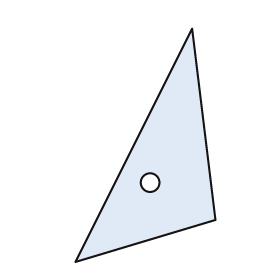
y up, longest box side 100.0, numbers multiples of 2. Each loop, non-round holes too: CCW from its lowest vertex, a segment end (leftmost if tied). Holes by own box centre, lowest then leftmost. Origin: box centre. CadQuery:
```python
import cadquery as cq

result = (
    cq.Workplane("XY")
    .moveTo(-30.0, -50.0)
    .lineTo(30.0, -32.0)
    .lineTo(20.0, 50.0)
    .close()
    .moveTo(2.0, -16.0)
    .circle(4.0)
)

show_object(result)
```